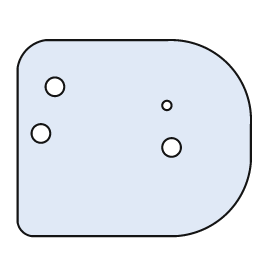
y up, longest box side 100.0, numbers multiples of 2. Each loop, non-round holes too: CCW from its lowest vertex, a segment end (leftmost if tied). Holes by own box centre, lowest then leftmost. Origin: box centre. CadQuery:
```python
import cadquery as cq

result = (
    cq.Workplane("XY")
    .moveTo(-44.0, -42.0)
    .lineTo(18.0, -42.0)
    .threePointArc((40.0, -32.0), (50.0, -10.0))
    .lineTo(50.0, 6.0)
    .threePointArc((40.0, 32.0), (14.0, 42.0))
    .lineTo(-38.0, 42.0)
    .threePointArc((-46.0, 38.0), (-50.0, 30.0))
    .lineTo(-50.0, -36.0)
    .threePointArc((-48.0, -40.0), (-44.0, -42.0))
    .close()
    .moveTo(16.0, -4.0)
    .circle(4.0)
    .moveTo(-40.0, 2.0)
    .circle(4.0)
    .moveTo(14.0, 14.0)
    .circle(2.0)
    .moveTo(-34.0, 22.0)
    .circle(4.0)
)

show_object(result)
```